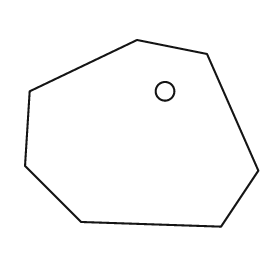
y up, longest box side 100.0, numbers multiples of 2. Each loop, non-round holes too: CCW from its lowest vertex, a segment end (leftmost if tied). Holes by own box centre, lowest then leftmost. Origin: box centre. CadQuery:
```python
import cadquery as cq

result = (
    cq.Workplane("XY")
    .moveTo(34.0, -40.0)
    .lineTo(50.0, -16.0)
    .lineTo(28.0, 34.0)
    .lineTo(-2.0, 40.0)
    .lineTo(-48.0, 18.0)
    .lineTo(-50.0, -14.0)
    .lineTo(-26.0, -38.0)
    .close()
    .moveTo(10.0, 18.0)
    .circle(4.0)
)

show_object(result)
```